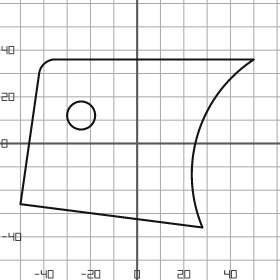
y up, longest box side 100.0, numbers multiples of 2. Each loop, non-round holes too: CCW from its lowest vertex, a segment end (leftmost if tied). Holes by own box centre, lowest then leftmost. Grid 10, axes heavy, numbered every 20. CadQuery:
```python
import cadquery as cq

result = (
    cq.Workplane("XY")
    .moveTo(28.0, -36.0)
    .threePointArc((26.0, 4.0), (50.0, 36.0))
    .lineTo(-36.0, 36.0)
    .threePointArc((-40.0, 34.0), (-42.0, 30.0))
    .lineTo(-50.0, -26.0)
    .close()
    .moveTo(-24.0, 12.0)
    .circle(6.0)
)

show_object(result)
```